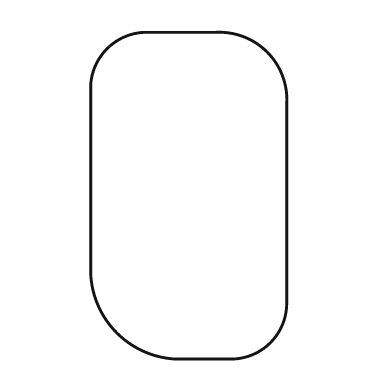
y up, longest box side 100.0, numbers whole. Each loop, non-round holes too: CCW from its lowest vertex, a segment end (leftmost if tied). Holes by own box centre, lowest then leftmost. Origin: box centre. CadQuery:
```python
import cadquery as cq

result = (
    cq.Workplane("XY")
    .moveTo(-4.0, -50.0)
    .lineTo(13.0, -50.0)
    .threePointArc((25.0, -45.0), (30.0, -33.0))
    .lineTo(30.0, 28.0)
    .threePointArc((24.0, 44.0), (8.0, 50.0))
    .lineTo(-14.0, 50.0)
    .threePointArc((-25.0, 45.0), (-30.0, 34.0))
    .lineTo(-30.0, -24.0)
    .threePointArc((-22.0, -42.0), (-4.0, -50.0))
    .close()
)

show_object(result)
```